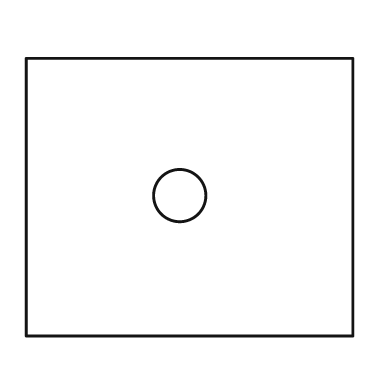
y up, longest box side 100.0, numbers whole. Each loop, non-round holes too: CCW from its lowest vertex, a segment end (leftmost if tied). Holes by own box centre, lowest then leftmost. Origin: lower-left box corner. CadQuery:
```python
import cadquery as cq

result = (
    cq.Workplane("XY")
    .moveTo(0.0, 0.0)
    .lineTo(100.0, 0.0)
    .lineTo(100.0, 85.0)
    .lineTo(0.0, 85.0)
    .close()
    .moveTo(47.0, 43.0)
    .circle(8.0)
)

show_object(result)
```